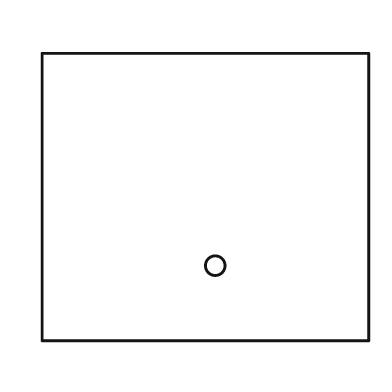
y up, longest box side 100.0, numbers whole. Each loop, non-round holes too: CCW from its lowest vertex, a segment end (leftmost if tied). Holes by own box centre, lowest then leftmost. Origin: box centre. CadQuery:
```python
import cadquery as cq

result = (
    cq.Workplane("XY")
    .moveTo(-50.0, -44.0)
    .lineTo(50.0, -44.0)
    .lineTo(50.0, 44.0)
    .lineTo(-50.0, 44.0)
    .close()
    .moveTo(3.0, -21.0)
    .circle(3.0)
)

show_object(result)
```